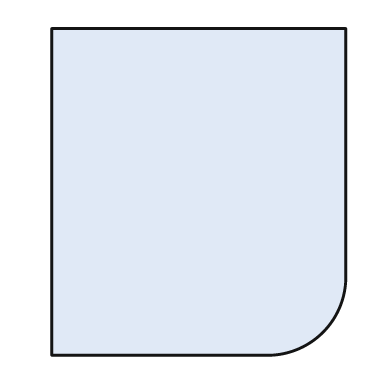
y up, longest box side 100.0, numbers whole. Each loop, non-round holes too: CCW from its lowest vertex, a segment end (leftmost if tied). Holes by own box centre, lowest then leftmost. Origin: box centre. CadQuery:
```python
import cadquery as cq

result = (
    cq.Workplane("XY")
    .moveTo(-45.0, -50.0)
    .lineTo(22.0, -50.0)
    .threePointArc((38.0, -43.0), (45.0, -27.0))
    .lineTo(45.0, 50.0)
    .lineTo(-45.0, 50.0)
    .close()
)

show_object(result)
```